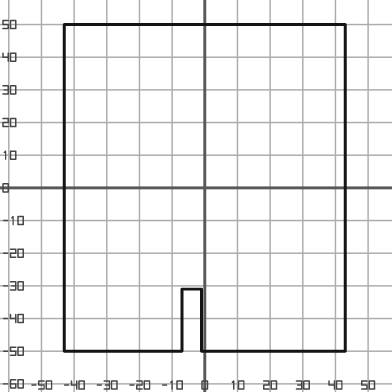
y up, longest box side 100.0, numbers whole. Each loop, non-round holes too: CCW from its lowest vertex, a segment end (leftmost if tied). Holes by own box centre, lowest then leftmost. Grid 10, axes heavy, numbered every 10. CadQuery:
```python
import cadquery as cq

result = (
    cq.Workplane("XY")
    .moveTo(-43.0, -50.0)
    .lineTo(-7.0, -50.0)
    .lineTo(-7.0, -31.0)
    .lineTo(-1.0, -31.0)
    .lineTo(-1.0, -50.0)
    .lineTo(43.0, -50.0)
    .lineTo(43.0, 50.0)
    .lineTo(-43.0, 50.0)
    .close()
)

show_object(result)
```